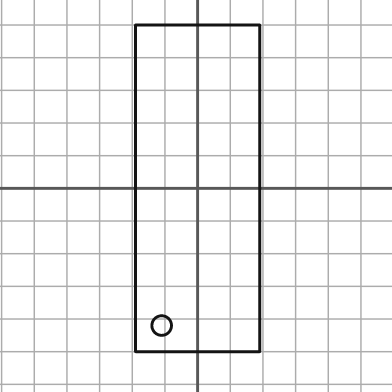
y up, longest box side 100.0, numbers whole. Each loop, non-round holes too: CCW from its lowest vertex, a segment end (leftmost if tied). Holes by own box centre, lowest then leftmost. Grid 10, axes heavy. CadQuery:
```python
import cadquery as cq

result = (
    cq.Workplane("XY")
    .moveTo(-19.0, -50.0)
    .lineTo(19.0, -50.0)
    .lineTo(19.0, 50.0)
    .lineTo(-19.0, 50.0)
    .close()
    .moveTo(-11.0, -42.0)
    .circle(3.0)
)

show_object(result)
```